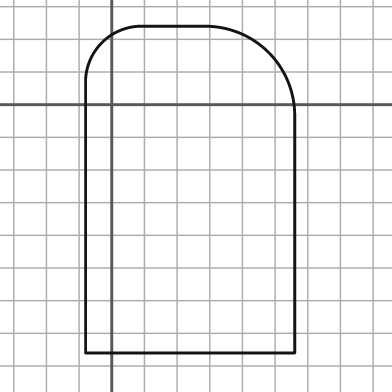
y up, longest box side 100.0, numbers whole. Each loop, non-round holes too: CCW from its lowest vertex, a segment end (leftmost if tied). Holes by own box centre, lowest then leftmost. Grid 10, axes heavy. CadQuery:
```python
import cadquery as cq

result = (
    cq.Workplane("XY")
    .moveTo(-8.0, -76.0)
    .lineTo(56.0, -76.0)
    .lineTo(56.0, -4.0)
    .threePointArc((48.0, 16.0), (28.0, 24.0))
    .lineTo(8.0, 24.0)
    .threePointArc((-3.0, 19.0), (-8.0, 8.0))
    .close()
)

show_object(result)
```